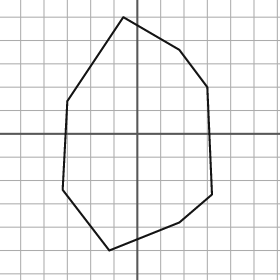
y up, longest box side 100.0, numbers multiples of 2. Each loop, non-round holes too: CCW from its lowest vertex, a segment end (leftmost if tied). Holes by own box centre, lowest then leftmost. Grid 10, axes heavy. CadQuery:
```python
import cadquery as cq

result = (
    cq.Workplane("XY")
    .moveTo(-12.0, -50.0)
    .lineTo(18.0, -38.0)
    .lineTo(32.0, -26.0)
    .lineTo(30.0, 20.0)
    .lineTo(18.0, 36.0)
    .lineTo(-6.0, 50.0)
    .lineTo(-30.0, 14.0)
    .lineTo(-32.0, -24.0)
    .close()
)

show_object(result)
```